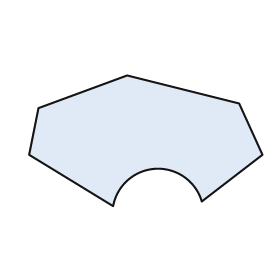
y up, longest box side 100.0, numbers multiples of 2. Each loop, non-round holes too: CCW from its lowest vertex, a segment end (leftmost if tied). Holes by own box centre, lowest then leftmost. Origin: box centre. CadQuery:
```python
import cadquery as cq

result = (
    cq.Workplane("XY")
    .moveTo(-14.0, -28.0)
    .threePointArc((4.0, -12.0), (24.0, -26.0))
    .lineTo(50.0, -6.0)
    .lineTo(40.0, 16.0)
    .lineTo(-8.0, 28.0)
    .lineTo(-46.0, 14.0)
    .lineTo(-50.0, -6.0)
    .close()
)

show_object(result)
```